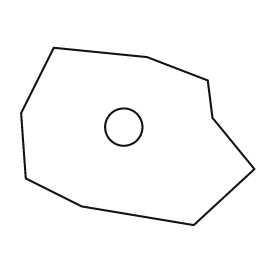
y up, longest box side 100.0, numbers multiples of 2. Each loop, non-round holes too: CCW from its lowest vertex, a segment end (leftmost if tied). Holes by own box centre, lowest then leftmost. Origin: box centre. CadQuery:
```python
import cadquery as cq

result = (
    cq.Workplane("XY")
    .moveTo(24.0, -38.0)
    .lineTo(50.0, -14.0)
    .lineTo(32.0, 8.0)
    .lineTo(30.0, 24.0)
    .lineTo(4.0, 34.0)
    .lineTo(-36.0, 38.0)
    .lineTo(-50.0, 10.0)
    .lineTo(-48.0, -18.0)
    .lineTo(-24.0, -30.0)
    .close()
    .moveTo(-6.0, 4.0)
    .circle(8.0)
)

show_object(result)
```